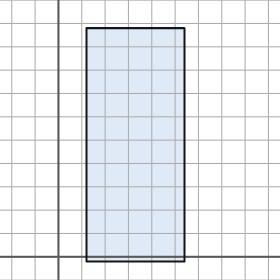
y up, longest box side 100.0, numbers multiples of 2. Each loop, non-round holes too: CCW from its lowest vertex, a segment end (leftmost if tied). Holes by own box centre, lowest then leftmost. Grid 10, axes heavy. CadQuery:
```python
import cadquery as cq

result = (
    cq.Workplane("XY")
    .moveTo(12.0, -2.0)
    .lineTo(54.0, -2.0)
    .lineTo(54.0, 98.0)
    .lineTo(12.0, 98.0)
    .close()
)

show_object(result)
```